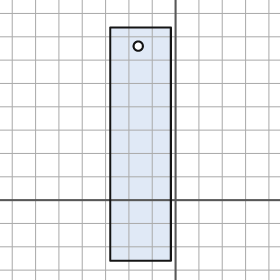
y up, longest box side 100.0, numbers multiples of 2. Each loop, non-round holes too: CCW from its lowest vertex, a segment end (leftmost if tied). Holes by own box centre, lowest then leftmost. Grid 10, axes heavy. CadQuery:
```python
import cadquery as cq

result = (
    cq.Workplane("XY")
    .moveTo(-28.0, -26.0)
    .lineTo(-2.0, -26.0)
    .lineTo(-2.0, 74.0)
    .lineTo(-28.0, 74.0)
    .close()
    .moveTo(-16.0, 66.0)
    .circle(2.0)
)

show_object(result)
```